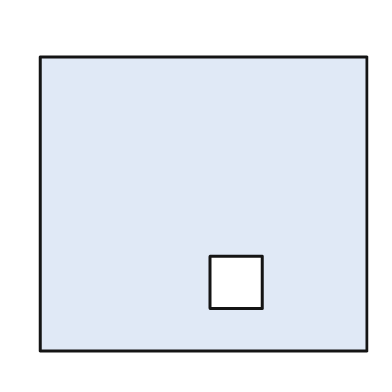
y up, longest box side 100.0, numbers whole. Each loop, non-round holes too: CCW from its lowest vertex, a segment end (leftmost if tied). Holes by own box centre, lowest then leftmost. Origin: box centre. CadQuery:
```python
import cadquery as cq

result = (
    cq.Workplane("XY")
    .moveTo(-50.0, -45.0)
    .lineTo(50.0, -45.0)
    .lineTo(50.0, 45.0)
    .lineTo(-50.0, 45.0)
    .close()
    .moveTo(2.0, -32.0)
    .lineTo(18.0, -32.0)
    .lineTo(18.0, -16.0)
    .lineTo(2.0, -16.0)
    .close()
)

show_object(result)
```